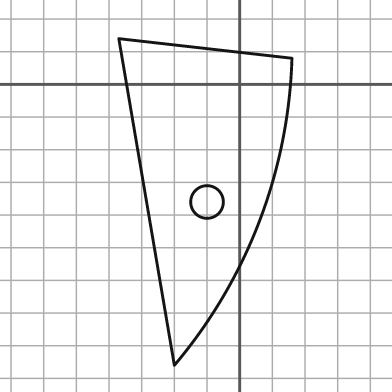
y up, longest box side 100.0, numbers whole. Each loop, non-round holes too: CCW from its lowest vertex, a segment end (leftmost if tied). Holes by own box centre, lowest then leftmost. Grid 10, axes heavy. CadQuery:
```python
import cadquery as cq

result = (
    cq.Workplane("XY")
    .moveTo(-20.0, -86.0)
    .threePointArc((6.0, -42.0), (16.0, 8.0))
    .lineTo(-37.0, 14.0)
    .close()
    .moveTo(-10.0, -36.0)
    .circle(5.0)
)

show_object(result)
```